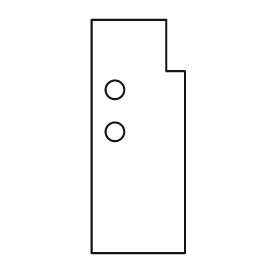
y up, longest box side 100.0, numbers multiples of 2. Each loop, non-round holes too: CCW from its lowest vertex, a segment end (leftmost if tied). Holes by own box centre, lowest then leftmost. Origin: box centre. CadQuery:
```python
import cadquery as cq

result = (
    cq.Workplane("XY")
    .moveTo(-20.0, -50.0)
    .lineTo(20.0, -50.0)
    .lineTo(20.0, 28.0)
    .lineTo(12.0, 28.0)
    .lineTo(12.0, 50.0)
    .lineTo(-20.0, 50.0)
    .close()
    .moveTo(-10.0, 2.0)
    .circle(4.0)
    .moveTo(-10.0, 20.0)
    .circle(4.0)
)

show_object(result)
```